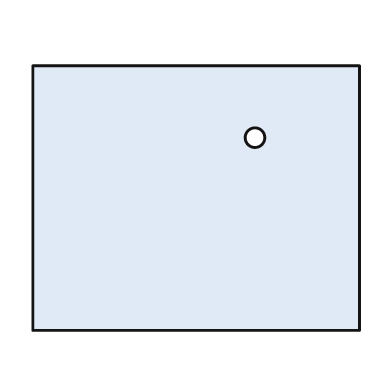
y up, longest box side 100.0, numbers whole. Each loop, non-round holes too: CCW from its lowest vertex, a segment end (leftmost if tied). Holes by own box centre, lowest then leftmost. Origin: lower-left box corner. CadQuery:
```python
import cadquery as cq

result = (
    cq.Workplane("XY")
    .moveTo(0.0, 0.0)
    .lineTo(100.0, 0.0)
    .lineTo(100.0, 81.0)
    .lineTo(0.0, 81.0)
    .close()
    .moveTo(68.0, 59.0)
    .circle(3.0)
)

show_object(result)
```